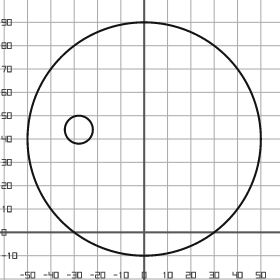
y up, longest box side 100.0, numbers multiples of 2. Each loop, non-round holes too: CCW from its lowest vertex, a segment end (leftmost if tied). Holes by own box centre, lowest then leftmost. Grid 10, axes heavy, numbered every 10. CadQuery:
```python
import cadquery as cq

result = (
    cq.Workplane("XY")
    .moveTo(0.0, 40.0)
    .circle(50.0)
    .moveTo(-28.0, 44.0)
    .circle(6.0)
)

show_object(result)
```